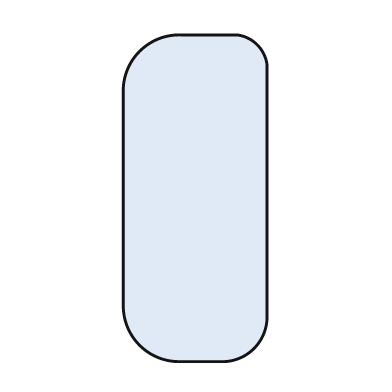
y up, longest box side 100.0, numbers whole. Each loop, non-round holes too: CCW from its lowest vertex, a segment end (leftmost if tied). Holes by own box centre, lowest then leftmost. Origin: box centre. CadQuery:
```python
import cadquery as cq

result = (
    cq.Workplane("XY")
    .moveTo(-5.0, -50.0)
    .lineTo(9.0, -50.0)
    .threePointArc((18.0, -46.0), (22.0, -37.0))
    .lineTo(22.0, 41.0)
    .threePointArc((19.0, 47.0), (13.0, 50.0))
    .lineTo(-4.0, 50.0)
    .threePointArc((-17.0, 45.0), (-22.0, 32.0))
    .lineTo(-22.0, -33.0)
    .threePointArc((-17.0, -45.0), (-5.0, -50.0))
    .close()
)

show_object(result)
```